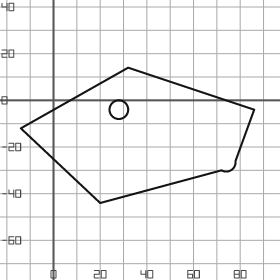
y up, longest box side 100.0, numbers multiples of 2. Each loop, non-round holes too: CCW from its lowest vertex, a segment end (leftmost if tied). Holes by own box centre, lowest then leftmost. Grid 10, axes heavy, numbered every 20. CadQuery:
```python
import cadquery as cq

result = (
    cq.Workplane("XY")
    .moveTo(20.0, -44.0)
    .lineTo(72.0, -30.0)
    .threePointArc((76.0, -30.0), (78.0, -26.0))
    .lineTo(86.0, -4.0)
    .lineTo(32.0, 14.0)
    .lineTo(-14.0, -12.0)
    .close()
    .moveTo(28.0, -4.0)
    .circle(4.0)
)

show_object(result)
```